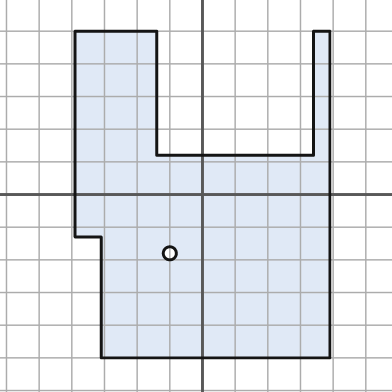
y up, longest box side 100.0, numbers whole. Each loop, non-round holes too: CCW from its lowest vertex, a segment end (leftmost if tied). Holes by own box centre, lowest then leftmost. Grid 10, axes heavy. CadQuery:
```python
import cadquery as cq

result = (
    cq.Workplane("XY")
    .moveTo(-31.0, -50.0)
    .lineTo(39.0, -50.0)
    .lineTo(39.0, 50.0)
    .lineTo(34.0, 50.0)
    .lineTo(34.0, 12.0)
    .lineTo(-14.0, 12.0)
    .lineTo(-14.0, 50.0)
    .lineTo(-39.0, 50.0)
    .lineTo(-39.0, -13.0)
    .lineTo(-31.0, -13.0)
    .close()
    .moveTo(-10.0, -18.0)
    .circle(2.0)
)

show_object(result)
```